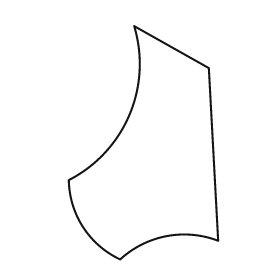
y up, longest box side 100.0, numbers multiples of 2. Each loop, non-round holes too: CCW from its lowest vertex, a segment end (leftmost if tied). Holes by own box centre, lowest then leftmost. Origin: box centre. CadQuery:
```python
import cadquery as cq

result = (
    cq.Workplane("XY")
    .moveTo(-10.0, -50.0)
    .threePointArc((10.0, -40.0), (32.0, -42.0))
    .lineTo(28.0, 32.0)
    .lineTo(-4.0, 50.0)
    .threePointArc((-6.0, 12.0), (-32.0, -16.0))
    .threePointArc((-26.0, -36.0), (-10.0, -50.0))
    .close()
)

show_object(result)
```